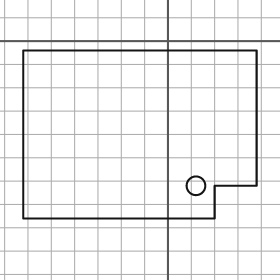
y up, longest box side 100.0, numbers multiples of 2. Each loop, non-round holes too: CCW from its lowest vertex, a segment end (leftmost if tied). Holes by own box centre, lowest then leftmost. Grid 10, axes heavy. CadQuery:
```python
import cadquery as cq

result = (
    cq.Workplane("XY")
    .moveTo(-62.0, -76.0)
    .lineTo(20.0, -76.0)
    .lineTo(20.0, -62.0)
    .lineTo(38.0, -62.0)
    .lineTo(38.0, -4.0)
    .lineTo(-62.0, -4.0)
    .close()
    .moveTo(12.0, -62.0)
    .circle(4.0)
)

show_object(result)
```